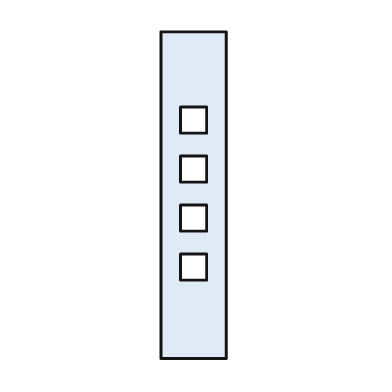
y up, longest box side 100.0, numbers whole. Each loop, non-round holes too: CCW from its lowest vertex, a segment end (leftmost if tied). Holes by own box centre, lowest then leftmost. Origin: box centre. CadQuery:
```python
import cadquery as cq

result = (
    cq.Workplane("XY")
    .moveTo(-10.0, -50.0)
    .lineTo(10.0, -50.0)
    .lineTo(10.0, 50.0)
    .lineTo(-10.0, 50.0)
    .close()
    .moveTo(-4.0, -26.0)
    .lineTo(4.0, -26.0)
    .lineTo(4.0, -18.0)
    .lineTo(-4.0, -18.0)
    .close()
    .moveTo(-4.0, -11.0)
    .lineTo(4.0, -11.0)
    .lineTo(4.0, -3.0)
    .lineTo(-4.0, -3.0)
    .close()
    .moveTo(-4.0, 4.0)
    .lineTo(4.0, 4.0)
    .lineTo(4.0, 12.0)
    .lineTo(-4.0, 12.0)
    .close()
    .moveTo(-4.0, 19.0)
    .lineTo(4.0, 19.0)
    .lineTo(4.0, 27.0)
    .lineTo(-4.0, 27.0)
    .close()
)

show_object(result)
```